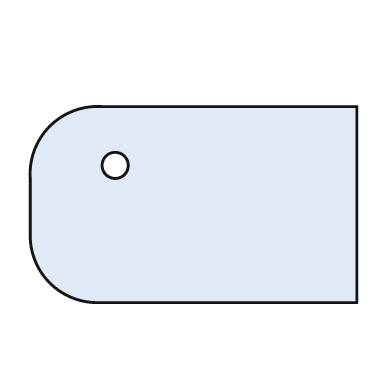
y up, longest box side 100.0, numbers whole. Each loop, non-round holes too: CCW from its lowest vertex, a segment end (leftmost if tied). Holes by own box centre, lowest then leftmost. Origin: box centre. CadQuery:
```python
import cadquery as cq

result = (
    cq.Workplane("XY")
    .moveTo(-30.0, -30.0)
    .lineTo(50.0, -30.0)
    .lineTo(50.0, 30.0)
    .lineTo(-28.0, 30.0)
    .threePointArc((-44.0, 24.0), (-50.0, 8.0))
    .lineTo(-50.0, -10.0)
    .threePointArc((-44.0, -24.0), (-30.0, -30.0))
    .close()
    .moveTo(-24.0, 12.0)
    .circle(4.0)
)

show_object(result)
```